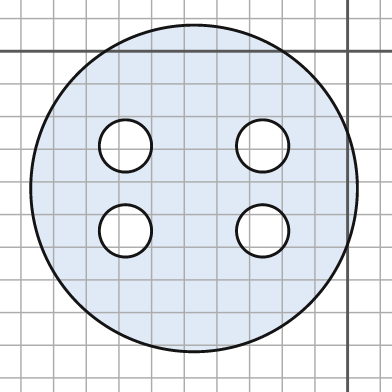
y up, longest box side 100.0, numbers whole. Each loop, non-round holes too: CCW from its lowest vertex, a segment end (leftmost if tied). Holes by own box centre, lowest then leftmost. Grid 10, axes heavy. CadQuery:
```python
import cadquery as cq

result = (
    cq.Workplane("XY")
    .moveTo(-47.0, -42.0)
    .circle(50.0)
    .moveTo(-68.0, -55.0)
    .circle(8.0)
    .moveTo(-26.0, -55.0)
    .circle(8.0)
    .moveTo(-68.0, -29.0)
    .circle(8.0)
    .moveTo(-26.0, -29.0)
    .circle(8.0)
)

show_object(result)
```